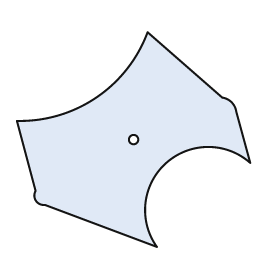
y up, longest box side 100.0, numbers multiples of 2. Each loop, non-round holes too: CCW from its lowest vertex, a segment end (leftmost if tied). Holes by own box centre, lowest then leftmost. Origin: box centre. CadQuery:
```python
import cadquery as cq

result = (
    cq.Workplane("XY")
    .moveTo(10.0, -46.0)
    .threePointArc((14.0, -10.0), (50.0, -10.0))
    .lineTo(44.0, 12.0)
    .threePointArc((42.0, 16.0), (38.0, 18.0))
    .lineTo(6.0, 46.0)
    .threePointArc((-16.0, 18.0), (-50.0, 8.0))
    .lineTo(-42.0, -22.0)
    .threePointArc((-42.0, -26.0), (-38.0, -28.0))
    .close()
    .moveTo(0.0, 0.0)
    .circle(2.0)
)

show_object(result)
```